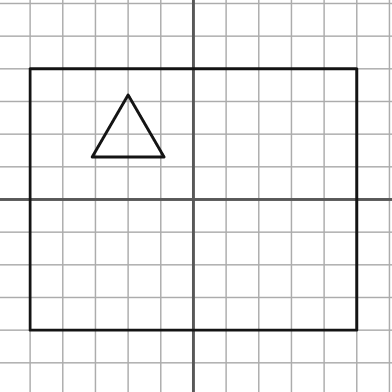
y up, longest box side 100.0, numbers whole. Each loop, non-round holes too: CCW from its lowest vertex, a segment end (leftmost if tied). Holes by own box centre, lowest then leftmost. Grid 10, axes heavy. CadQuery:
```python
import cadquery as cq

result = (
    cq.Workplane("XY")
    .moveTo(-50.0, -40.0)
    .lineTo(50.0, -40.0)
    .lineTo(50.0, 40.0)
    .lineTo(-50.0, 40.0)
    .close()
    .moveTo(-31.0, 13.0)
    .lineTo(-9.0, 13.0)
    .lineTo(-20.0, 32.0)
    .close()
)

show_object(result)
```